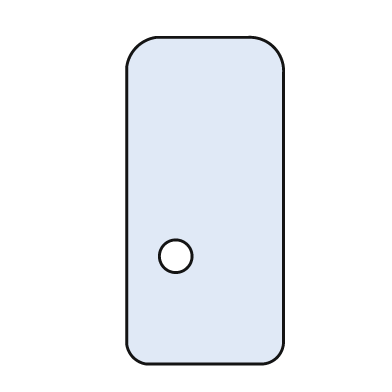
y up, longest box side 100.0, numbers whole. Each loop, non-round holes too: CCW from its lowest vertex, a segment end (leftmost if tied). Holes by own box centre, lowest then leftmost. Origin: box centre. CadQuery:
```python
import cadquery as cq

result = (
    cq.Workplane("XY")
    .moveTo(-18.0, -50.0)
    .lineTo(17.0, -50.0)
    .threePointArc((22.0, -48.0), (24.0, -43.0))
    .lineTo(24.0, 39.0)
    .threePointArc((21.0, 47.0), (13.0, 50.0))
    .lineTo(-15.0, 50.0)
    .threePointArc((-21.0, 47.0), (-24.0, 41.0))
    .lineTo(-24.0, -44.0)
    .threePointArc((-22.0, -48.0), (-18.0, -50.0))
    .close()
    .moveTo(-9.0, -17.0)
    .circle(5.0)
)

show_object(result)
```